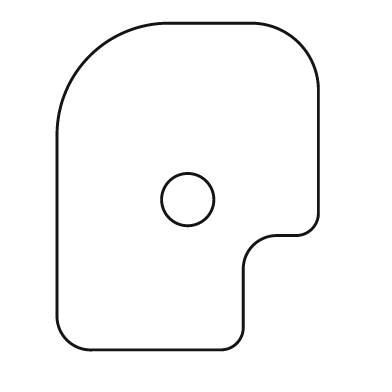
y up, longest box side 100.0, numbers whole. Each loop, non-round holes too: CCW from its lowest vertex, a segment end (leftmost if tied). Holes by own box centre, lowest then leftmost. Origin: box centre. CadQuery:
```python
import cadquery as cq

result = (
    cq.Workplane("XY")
    .moveTo(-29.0, -50.0)
    .lineTo(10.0, -50.0)
    .threePointArc((15.0, -48.0), (17.0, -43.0))
    .lineTo(17.0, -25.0)
    .threePointArc((20.0, -18.0), (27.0, -15.0))
    .lineTo(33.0, -15.0)
    .threePointArc((38.0, -13.0), (40.0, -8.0))
    .lineTo(40.0, 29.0)
    .threePointArc((34.0, 44.0), (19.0, 50.0))
    .lineTo(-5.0, 50.0)
    .threePointArc((-30.0, 40.0), (-40.0, 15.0))
    .lineTo(-40.0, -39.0)
    .threePointArc((-37.0, -47.0), (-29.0, -50.0))
    .close()
    .moveTo(0.0, -4.0)
    .circle(8.0)
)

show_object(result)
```